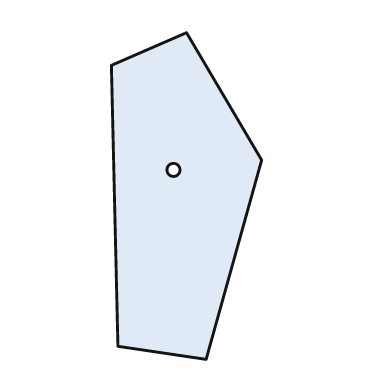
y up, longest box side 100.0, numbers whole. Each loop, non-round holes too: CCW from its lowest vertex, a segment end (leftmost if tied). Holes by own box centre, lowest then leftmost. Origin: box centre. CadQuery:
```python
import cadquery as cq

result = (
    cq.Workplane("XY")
    .moveTo(6.0, -50.0)
    .lineTo(23.0, 11.0)
    .lineTo(0.0, 50.0)
    .lineTo(-23.0, 40.0)
    .lineTo(-21.0, -46.0)
    .close()
    .moveTo(-4.0, 8.0)
    .circle(2.0)
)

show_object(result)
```